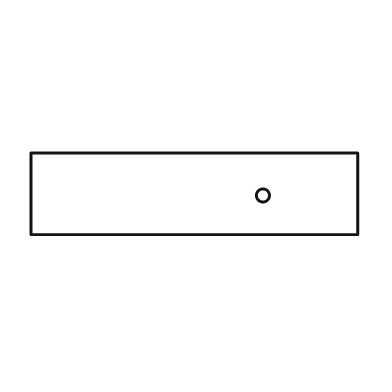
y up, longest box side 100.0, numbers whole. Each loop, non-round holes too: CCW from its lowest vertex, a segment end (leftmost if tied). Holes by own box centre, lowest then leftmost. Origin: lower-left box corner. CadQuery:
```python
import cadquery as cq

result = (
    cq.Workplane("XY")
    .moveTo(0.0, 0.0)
    .lineTo(100.0, 0.0)
    .lineTo(100.0, 25.0)
    .lineTo(0.0, 25.0)
    .close()
    .moveTo(71.0, 12.0)
    .circle(2.0)
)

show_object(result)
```